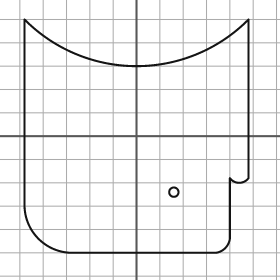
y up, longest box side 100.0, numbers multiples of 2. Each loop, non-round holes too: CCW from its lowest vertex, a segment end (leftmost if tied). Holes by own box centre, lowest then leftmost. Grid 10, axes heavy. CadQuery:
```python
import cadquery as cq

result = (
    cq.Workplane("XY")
    .moveTo(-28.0, -50.0)
    .lineTo(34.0, -50.0)
    .threePointArc((38.0, -48.0), (40.0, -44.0))
    .lineTo(40.0, -18.0)
    .threePointArc((44.0, -20.0), (48.0, -18.0))
    .lineTo(48.0, 50.0)
    .threePointArc((0.0, 30.0), (-48.0, 50.0))
    .lineTo(-48.0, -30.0)
    .threePointArc((-42.0, -44.0), (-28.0, -50.0))
    .close()
    .moveTo(16.0, -24.0)
    .circle(2.0)
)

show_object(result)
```